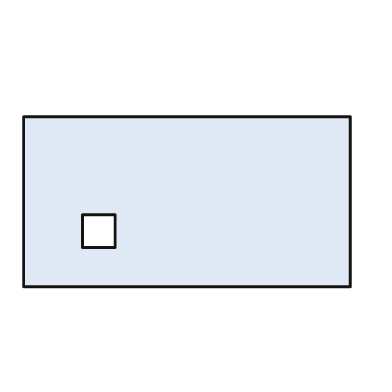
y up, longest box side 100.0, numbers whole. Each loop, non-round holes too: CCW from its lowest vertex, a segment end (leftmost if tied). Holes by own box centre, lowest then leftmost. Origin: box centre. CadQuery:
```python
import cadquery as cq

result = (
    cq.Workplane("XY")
    .moveTo(-50.0, -26.0)
    .lineTo(50.0, -26.0)
    .lineTo(50.0, 26.0)
    .lineTo(-50.0, 26.0)
    .close()
    .moveTo(-32.0, -14.0)
    .lineTo(-22.0, -14.0)
    .lineTo(-22.0, -4.0)
    .lineTo(-32.0, -4.0)
    .close()
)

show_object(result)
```